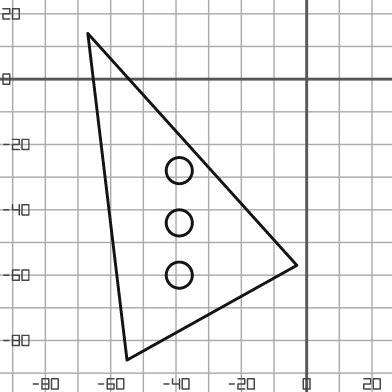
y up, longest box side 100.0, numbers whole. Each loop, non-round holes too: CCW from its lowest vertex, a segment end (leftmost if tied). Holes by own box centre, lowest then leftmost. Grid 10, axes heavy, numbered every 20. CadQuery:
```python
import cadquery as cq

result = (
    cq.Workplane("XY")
    .moveTo(-55.0, -86.0)
    .lineTo(-3.0, -57.0)
    .lineTo(-67.0, 14.0)
    .close()
    .moveTo(-39.0, -60.0)
    .circle(4.0)
    .moveTo(-39.0, -44.0)
    .circle(4.0)
    .moveTo(-39.0, -28.0)
    .circle(4.0)
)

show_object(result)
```